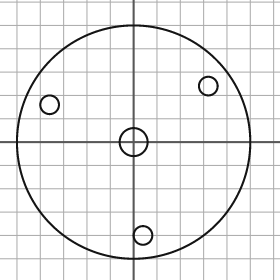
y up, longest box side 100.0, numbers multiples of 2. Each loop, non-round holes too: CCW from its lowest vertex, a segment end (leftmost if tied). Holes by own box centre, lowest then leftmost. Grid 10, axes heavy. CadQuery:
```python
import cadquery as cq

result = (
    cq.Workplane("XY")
    .moveTo(0.0, 0.0)
    .circle(50.0)
    .moveTo(4.0, -40.0)
    .circle(4.0)
    .moveTo(0.0, 0.0)
    .circle(6.0)
    .moveTo(-36.0, 16.0)
    .circle(4.0)
    .moveTo(32.0, 24.0)
    .circle(4.0)
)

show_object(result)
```